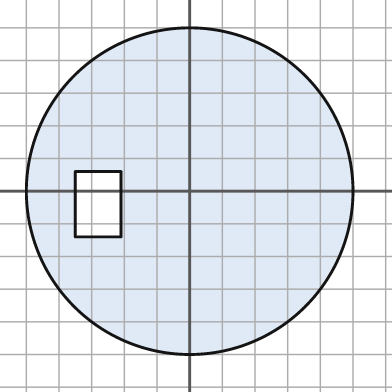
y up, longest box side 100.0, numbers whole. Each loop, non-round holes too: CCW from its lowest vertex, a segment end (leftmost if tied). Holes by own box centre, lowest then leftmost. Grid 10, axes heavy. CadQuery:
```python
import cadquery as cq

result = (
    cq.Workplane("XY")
    .moveTo(0.0, 0.0)
    .circle(50.0)
    .moveTo(-35.0, -14.0)
    .lineTo(-21.0, -14.0)
    .lineTo(-21.0, 6.0)
    .lineTo(-35.0, 6.0)
    .close()
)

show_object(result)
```